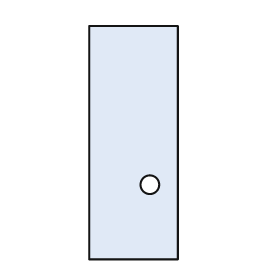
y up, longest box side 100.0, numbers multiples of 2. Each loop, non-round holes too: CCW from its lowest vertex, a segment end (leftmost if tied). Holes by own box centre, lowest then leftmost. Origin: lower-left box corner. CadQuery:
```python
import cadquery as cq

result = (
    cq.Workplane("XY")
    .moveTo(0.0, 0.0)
    .lineTo(38.0, 0.0)
    .lineTo(38.0, 100.0)
    .lineTo(0.0, 100.0)
    .close()
    .moveTo(26.0, 32.0)
    .circle(4.0)
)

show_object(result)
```